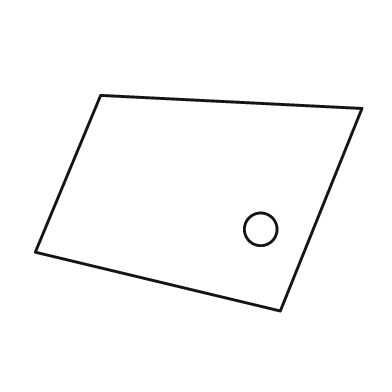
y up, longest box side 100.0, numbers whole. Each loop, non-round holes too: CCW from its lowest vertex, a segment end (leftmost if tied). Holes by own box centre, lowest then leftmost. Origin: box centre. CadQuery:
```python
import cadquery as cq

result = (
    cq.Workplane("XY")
    .moveTo(25.0, -33.0)
    .lineTo(50.0, 29.0)
    .lineTo(-30.0, 33.0)
    .lineTo(-50.0, -15.0)
    .close()
    .moveTo(19.0, -8.0)
    .circle(5.0)
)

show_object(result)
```